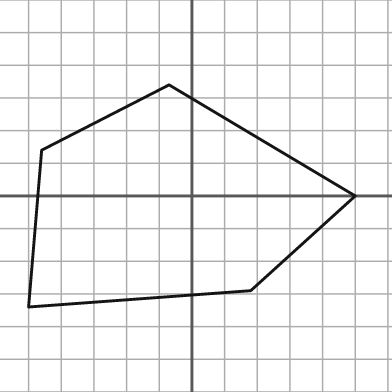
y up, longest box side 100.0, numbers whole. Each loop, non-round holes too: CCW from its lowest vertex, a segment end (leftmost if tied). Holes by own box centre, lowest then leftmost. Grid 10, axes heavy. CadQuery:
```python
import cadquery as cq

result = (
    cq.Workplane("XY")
    .moveTo(-50.0, -34.0)
    .lineTo(18.0, -29.0)
    .lineTo(50.0, 0.0)
    .lineTo(-7.0, 34.0)
    .lineTo(-46.0, 14.0)
    .close()
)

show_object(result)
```